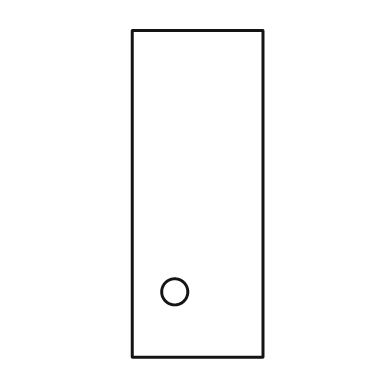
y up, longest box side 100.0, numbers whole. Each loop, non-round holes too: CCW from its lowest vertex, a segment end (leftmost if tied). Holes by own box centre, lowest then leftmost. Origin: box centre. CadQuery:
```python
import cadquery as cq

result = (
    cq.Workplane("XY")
    .moveTo(-20.0, -50.0)
    .lineTo(20.0, -50.0)
    .lineTo(20.0, 50.0)
    .lineTo(-20.0, 50.0)
    .close()
    .moveTo(-7.0, -30.0)
    .circle(4.0)
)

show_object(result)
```